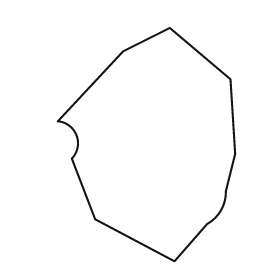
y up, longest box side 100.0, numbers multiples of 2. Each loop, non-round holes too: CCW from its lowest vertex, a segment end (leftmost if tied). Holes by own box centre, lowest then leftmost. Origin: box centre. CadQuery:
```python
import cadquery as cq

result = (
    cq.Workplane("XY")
    .moveTo(12.0, -50.0)
    .lineTo(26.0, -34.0)
    .threePointArc((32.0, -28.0), (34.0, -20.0))
    .lineTo(38.0, -4.0)
    .lineTo(36.0, 28.0)
    .lineTo(10.0, 50.0)
    .lineTo(-10.0, 40.0)
    .lineTo(-38.0, 10.0)
    .threePointArc((-30.0, 4.0), (-32.0, -6.0))
    .lineTo(-22.0, -32.0)
    .close()
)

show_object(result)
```